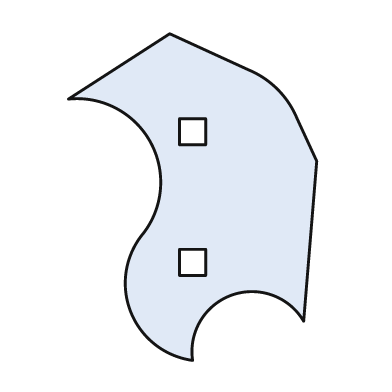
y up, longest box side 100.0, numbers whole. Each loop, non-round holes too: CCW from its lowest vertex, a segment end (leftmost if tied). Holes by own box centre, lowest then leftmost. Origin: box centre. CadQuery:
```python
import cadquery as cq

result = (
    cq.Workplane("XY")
    .moveTo(0.0, -50.0)
    .threePointArc((12.0, -30.0), (34.0, -38.0))
    .lineTo(38.0, 11.0)
    .lineTo(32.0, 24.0)
    .threePointArc((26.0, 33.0), (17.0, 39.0))
    .lineTo(-7.0, 50.0)
    .lineTo(-38.0, 30.0)
    .threePointArc((-13.0, 17.0), (-15.0, -11.0))
    .threePointArc((-19.0, -35.0), (0.0, -50.0))
    .close()
    .moveTo(-4.0, -24.0)
    .lineTo(4.0, -24.0)
    .lineTo(4.0, -16.0)
    .lineTo(-4.0, -16.0)
    .close()
    .moveTo(-4.0, 16.0)
    .lineTo(4.0, 16.0)
    .lineTo(4.0, 24.0)
    .lineTo(-4.0, 24.0)
    .close()
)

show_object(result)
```